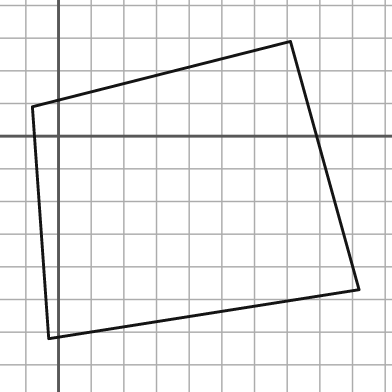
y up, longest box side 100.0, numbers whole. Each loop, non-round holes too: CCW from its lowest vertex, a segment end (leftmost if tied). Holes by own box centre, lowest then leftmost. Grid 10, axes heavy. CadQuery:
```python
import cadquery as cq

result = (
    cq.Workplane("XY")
    .moveTo(-3.0, -62.0)
    .lineTo(92.0, -47.0)
    .lineTo(71.0, 29.0)
    .lineTo(-8.0, 9.0)
    .close()
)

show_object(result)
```